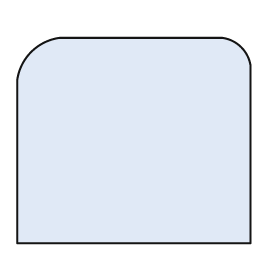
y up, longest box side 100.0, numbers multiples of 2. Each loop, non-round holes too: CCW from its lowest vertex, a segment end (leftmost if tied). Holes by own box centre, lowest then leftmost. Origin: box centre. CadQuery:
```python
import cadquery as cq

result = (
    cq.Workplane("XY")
    .moveTo(-50.0, -44.0)
    .lineTo(50.0, -44.0)
    .lineTo(50.0, 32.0)
    .threePointArc((46.0, 40.0), (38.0, 44.0))
    .lineTo(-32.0, 44.0)
    .threePointArc((-44.0, 38.0), (-50.0, 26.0))
    .close()
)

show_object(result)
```